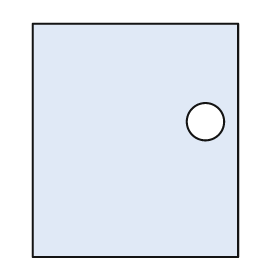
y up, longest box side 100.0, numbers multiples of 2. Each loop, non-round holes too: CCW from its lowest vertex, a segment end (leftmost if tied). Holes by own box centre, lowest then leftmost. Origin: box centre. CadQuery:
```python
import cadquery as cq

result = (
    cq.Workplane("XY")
    .moveTo(-44.0, -50.0)
    .lineTo(44.0, -50.0)
    .lineTo(44.0, 50.0)
    .lineTo(-44.0, 50.0)
    .close()
    .moveTo(30.0, 8.0)
    .circle(8.0)
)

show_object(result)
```